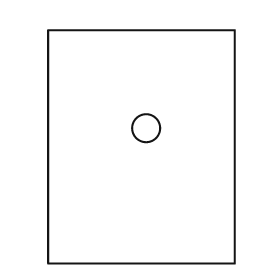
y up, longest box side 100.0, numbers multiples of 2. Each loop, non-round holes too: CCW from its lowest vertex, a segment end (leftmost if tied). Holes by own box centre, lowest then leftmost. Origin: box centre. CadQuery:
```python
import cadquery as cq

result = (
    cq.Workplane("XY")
    .moveTo(-40.0, -50.0)
    .lineTo(40.0, -50.0)
    .lineTo(40.0, 50.0)
    .lineTo(-40.0, 50.0)
    .close()
    .moveTo(2.0, 8.0)
    .circle(6.0)
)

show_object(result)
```